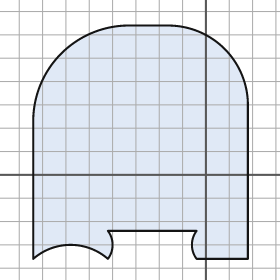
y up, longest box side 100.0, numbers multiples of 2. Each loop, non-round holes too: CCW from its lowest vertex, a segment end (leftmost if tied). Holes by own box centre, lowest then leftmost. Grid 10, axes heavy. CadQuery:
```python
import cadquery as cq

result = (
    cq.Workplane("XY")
    .moveTo(-74.0, -36.0)
    .threePointArc((-58.0, -30.0), (-42.0, -36.0))
    .threePointArc((-40.0, -30.0), (-42.0, -24.0))
    .lineTo(-4.0, -24.0)
    .threePointArc((-6.0, -30.0), (-4.0, -36.0))
    .lineTo(18.0, -36.0)
    .lineTo(18.0, 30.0)
    .threePointArc((8.0, 54.0), (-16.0, 64.0))
    .lineTo(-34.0, 64.0)
    .threePointArc((-62.0, 52.0), (-74.0, 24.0))
    .close()
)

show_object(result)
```